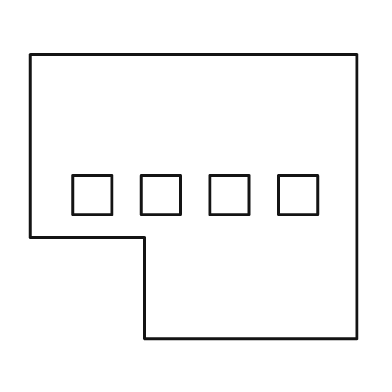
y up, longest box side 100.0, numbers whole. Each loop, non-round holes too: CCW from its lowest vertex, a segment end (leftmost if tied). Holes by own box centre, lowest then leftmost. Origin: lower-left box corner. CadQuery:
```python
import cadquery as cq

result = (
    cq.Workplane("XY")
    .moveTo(35.0, 0.0)
    .lineTo(100.0, 0.0)
    .lineTo(100.0, 87.0)
    .lineTo(0.0, 87.0)
    .lineTo(0.0, 31.0)
    .lineTo(35.0, 31.0)
    .close()
    .moveTo(13.0, 38.0)
    .lineTo(25.0, 38.0)
    .lineTo(25.0, 50.0)
    .lineTo(13.0, 50.0)
    .close()
    .moveTo(34.0, 38.0)
    .lineTo(46.0, 38.0)
    .lineTo(46.0, 50.0)
    .lineTo(34.0, 50.0)
    .close()
    .moveTo(55.0, 38.0)
    .lineTo(67.0, 38.0)
    .lineTo(67.0, 50.0)
    .lineTo(55.0, 50.0)
    .close()
    .moveTo(76.0, 38.0)
    .lineTo(88.0, 38.0)
    .lineTo(88.0, 50.0)
    .lineTo(76.0, 50.0)
    .close()
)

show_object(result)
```